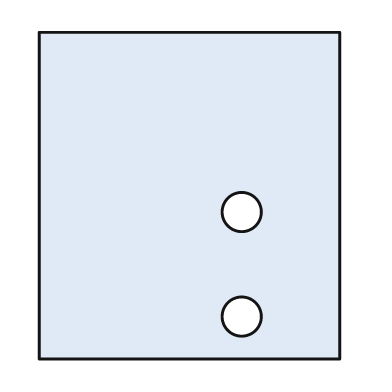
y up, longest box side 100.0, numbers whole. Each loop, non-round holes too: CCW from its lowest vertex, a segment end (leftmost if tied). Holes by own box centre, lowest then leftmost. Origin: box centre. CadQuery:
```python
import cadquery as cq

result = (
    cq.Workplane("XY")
    .moveTo(-46.0, -50.0)
    .lineTo(46.0, -50.0)
    .lineTo(46.0, 50.0)
    .lineTo(-46.0, 50.0)
    .close()
    .moveTo(16.0, -37.0)
    .circle(6.0)
    .moveTo(16.0, -5.0)
    .circle(6.0)
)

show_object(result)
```